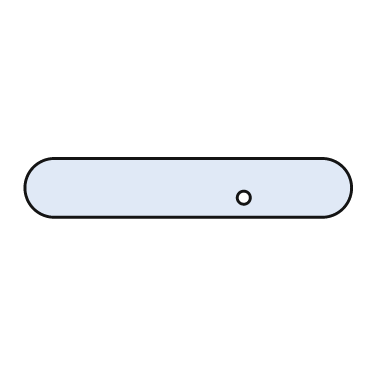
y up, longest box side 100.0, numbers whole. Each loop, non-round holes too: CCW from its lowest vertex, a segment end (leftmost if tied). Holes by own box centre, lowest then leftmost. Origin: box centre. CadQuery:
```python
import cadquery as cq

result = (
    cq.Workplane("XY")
    .moveTo(-41.0, -9.0)
    .lineTo(41.0, -9.0)
    .threePointArc((50.0, 0.0), (41.0, 9.0))
    .lineTo(-41.0, 9.0)
    .threePointArc((-50.0, 0.0), (-41.0, -9.0))
    .close()
    .moveTo(17.0, -3.0)
    .circle(2.0)
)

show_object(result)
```